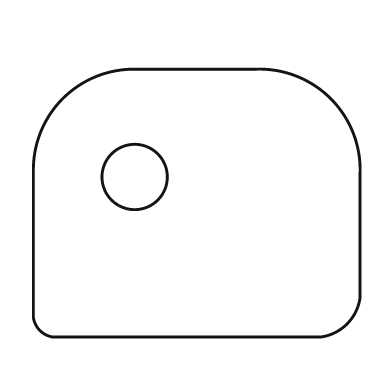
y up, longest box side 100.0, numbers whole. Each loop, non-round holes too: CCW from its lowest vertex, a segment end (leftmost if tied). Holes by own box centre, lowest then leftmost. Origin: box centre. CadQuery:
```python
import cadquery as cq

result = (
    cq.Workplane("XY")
    .moveTo(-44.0, -41.0)
    .lineTo(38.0, -41.0)
    .threePointArc((46.0, -37.0), (50.0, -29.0))
    .lineTo(50.0, 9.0)
    .threePointArc((41.0, 32.0), (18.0, 41.0))
    .lineTo(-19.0, 41.0)
    .threePointArc((-41.0, 32.0), (-50.0, 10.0))
    .lineTo(-50.0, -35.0)
    .threePointArc((-48.0, -39.0), (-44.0, -41.0))
    .close()
    .moveTo(-19.0, 8.0)
    .circle(10.0)
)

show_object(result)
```